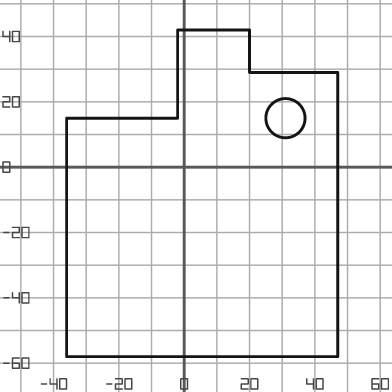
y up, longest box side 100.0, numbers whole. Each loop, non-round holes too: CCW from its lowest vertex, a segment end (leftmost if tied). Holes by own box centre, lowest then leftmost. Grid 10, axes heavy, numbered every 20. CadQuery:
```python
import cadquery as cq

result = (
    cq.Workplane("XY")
    .moveTo(-36.0, -58.0)
    .lineTo(47.0, -58.0)
    .lineTo(47.0, 29.0)
    .lineTo(20.0, 29.0)
    .lineTo(20.0, 42.0)
    .lineTo(-2.0, 42.0)
    .lineTo(-2.0, 15.0)
    .lineTo(-36.0, 15.0)
    .close()
    .moveTo(31.0, 15.0)
    .circle(6.0)
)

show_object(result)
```